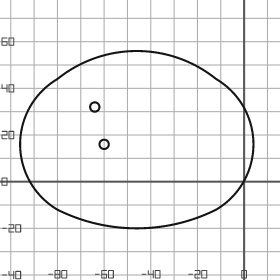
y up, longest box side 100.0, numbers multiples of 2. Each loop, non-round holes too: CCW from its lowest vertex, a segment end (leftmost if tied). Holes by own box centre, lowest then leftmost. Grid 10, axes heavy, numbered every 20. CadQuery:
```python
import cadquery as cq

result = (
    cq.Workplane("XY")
    .moveTo(-80.0, -12.0)
    .threePointArc((-46.0, -20.0), (-12.0, -12.0))
    .threePointArc((4.0, 16.0), (-12.0, 44.0))
    .threePointArc((-46.0, 56.0), (-80.0, 44.0))
    .threePointArc((-96.0, 16.0), (-80.0, -12.0))
    .close()
    .moveTo(-60.0, 16.0)
    .circle(2.0)
    .moveTo(-64.0, 32.0)
    .circle(2.0)
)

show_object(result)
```